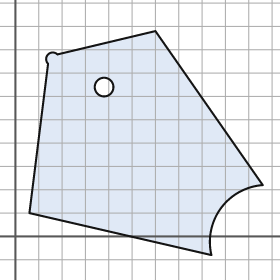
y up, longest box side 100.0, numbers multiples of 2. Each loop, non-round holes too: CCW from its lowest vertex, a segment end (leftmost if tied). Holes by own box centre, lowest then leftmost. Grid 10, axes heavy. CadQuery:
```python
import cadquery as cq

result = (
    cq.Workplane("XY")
    .moveTo(84.0, -8.0)
    .threePointArc((88.0, 12.0), (106.0, 22.0))
    .lineTo(60.0, 88.0)
    .lineTo(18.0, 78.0)
    .threePointArc((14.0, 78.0), (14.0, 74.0))
    .lineTo(6.0, 10.0)
    .close()
    .moveTo(38.0, 64.0)
    .circle(4.0)
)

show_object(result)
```